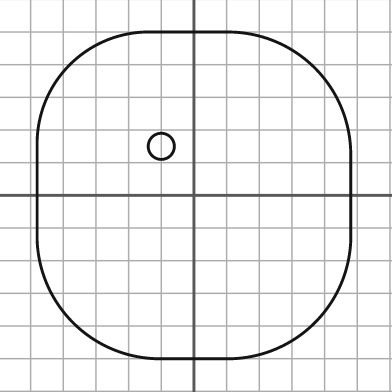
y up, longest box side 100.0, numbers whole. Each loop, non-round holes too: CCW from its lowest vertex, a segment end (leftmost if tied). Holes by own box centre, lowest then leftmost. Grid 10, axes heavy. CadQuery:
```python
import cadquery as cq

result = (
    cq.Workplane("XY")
    .moveTo(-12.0, -50.0)
    .lineTo(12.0, -50.0)
    .threePointArc((37.0, -39.0), (48.0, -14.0))
    .lineTo(48.0, 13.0)
    .threePointArc((37.0, 39.0), (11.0, 50.0))
    .lineTo(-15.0, 50.0)
    .threePointArc((-38.0, 40.0), (-48.0, 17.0))
    .lineTo(-48.0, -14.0)
    .threePointArc((-37.0, -39.0), (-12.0, -50.0))
    .close()
    .moveTo(-10.0, 15.0)
    .circle(4.0)
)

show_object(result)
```